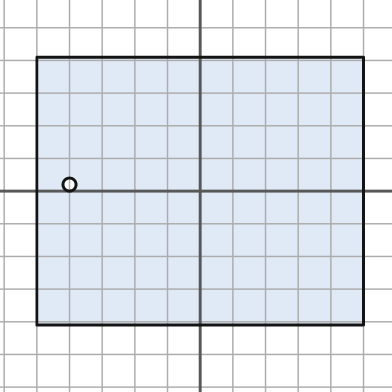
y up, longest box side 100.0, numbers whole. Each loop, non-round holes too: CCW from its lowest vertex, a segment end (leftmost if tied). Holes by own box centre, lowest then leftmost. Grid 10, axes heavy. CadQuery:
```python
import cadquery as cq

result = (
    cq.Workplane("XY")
    .moveTo(-50.0, -41.0)
    .lineTo(50.0, -41.0)
    .lineTo(50.0, 41.0)
    .lineTo(-50.0, 41.0)
    .close()
    .moveTo(-40.0, 2.0)
    .circle(2.0)
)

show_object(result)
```